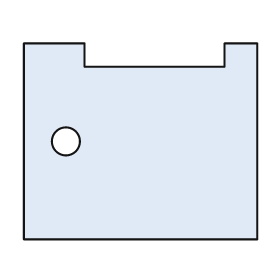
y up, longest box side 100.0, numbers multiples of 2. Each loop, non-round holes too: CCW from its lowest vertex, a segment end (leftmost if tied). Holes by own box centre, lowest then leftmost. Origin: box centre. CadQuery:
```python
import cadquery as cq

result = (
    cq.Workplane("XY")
    .moveTo(-50.0, -42.0)
    .lineTo(50.0, -42.0)
    .lineTo(50.0, 42.0)
    .lineTo(36.0, 42.0)
    .lineTo(36.0, 32.0)
    .lineTo(-24.0, 32.0)
    .lineTo(-24.0, 42.0)
    .lineTo(-50.0, 42.0)
    .close()
    .moveTo(-32.0, 0.0)
    .circle(6.0)
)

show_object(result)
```